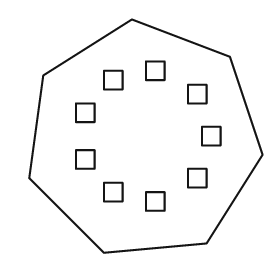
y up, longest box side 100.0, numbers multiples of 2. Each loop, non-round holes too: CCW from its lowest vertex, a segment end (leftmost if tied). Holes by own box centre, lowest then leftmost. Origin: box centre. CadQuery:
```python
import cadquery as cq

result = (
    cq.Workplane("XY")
    .moveTo(-18.0, -50.0)
    .lineTo(26.0, -46.0)
    .lineTo(50.0, -8.0)
    .lineTo(36.0, 34.0)
    .lineTo(-6.0, 50.0)
    .lineTo(-44.0, 26.0)
    .lineTo(-50.0, -18.0)
    .close()
    .moveTo(0.0, -32.0)
    .lineTo(8.0, -32.0)
    .lineTo(8.0, -24.0)
    .lineTo(0.0, -24.0)
    .close()
    .moveTo(-18.0, -28.0)
    .lineTo(-10.0, -28.0)
    .lineTo(-10.0, -20.0)
    .lineTo(-18.0, -20.0)
    .close()
    .moveTo(18.0, -22.0)
    .lineTo(26.0, -22.0)
    .lineTo(26.0, -14.0)
    .lineTo(18.0, -14.0)
    .close()
    .moveTo(-30.0, -14.0)
    .lineTo(-22.0, -14.0)
    .lineTo(-22.0, -6.0)
    .lineTo(-30.0, -6.0)
    .close()
    .moveTo(24.0, -4.0)
    .lineTo(32.0, -4.0)
    .lineTo(32.0, 4.0)
    .lineTo(24.0, 4.0)
    .close()
    .moveTo(-30.0, 6.0)
    .lineTo(-22.0, 6.0)
    .lineTo(-22.0, 14.0)
    .lineTo(-30.0, 14.0)
    .close()
    .moveTo(18.0, 14.0)
    .lineTo(26.0, 14.0)
    .lineTo(26.0, 22.0)
    .lineTo(18.0, 22.0)
    .close()
    .moveTo(-18.0, 20.0)
    .lineTo(-10.0, 20.0)
    .lineTo(-10.0, 28.0)
    .lineTo(-18.0, 28.0)
    .close()
    .moveTo(0.0, 24.0)
    .lineTo(8.0, 24.0)
    .lineTo(8.0, 32.0)
    .lineTo(0.0, 32.0)
    .close()
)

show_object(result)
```